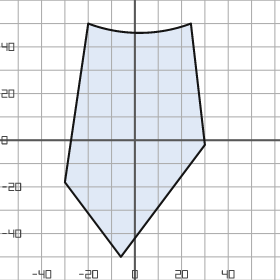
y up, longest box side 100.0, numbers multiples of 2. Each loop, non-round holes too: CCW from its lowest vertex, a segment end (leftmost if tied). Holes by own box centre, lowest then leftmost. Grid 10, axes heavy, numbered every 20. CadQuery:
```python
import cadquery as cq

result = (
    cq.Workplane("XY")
    .moveTo(-6.0, -50.0)
    .lineTo(30.0, -2.0)
    .lineTo(24.0, 50.0)
    .threePointArc((2.0, 46.0), (-20.0, 50.0))
    .lineTo(-30.0, -18.0)
    .close()
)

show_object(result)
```